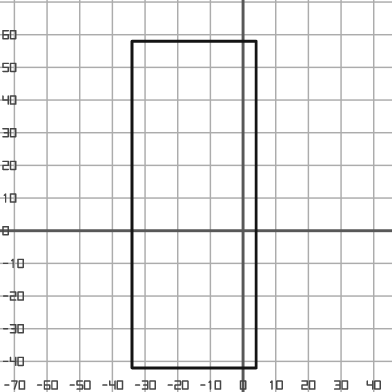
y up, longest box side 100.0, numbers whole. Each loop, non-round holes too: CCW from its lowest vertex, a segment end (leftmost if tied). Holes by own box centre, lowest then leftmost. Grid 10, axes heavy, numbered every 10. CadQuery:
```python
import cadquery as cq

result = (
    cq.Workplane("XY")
    .moveTo(-34.0, -42.0)
    .lineTo(4.0, -42.0)
    .lineTo(4.0, 58.0)
    .lineTo(-34.0, 58.0)
    .close()
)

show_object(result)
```